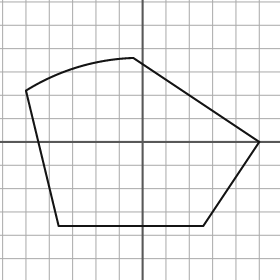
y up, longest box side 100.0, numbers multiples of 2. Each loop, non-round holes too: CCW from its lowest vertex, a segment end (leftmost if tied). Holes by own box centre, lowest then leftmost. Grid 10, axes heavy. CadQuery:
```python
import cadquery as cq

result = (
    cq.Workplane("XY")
    .moveTo(-36.0, -36.0)
    .lineTo(26.0, -36.0)
    .lineTo(50.0, 0.0)
    .lineTo(-4.0, 36.0)
    .threePointArc((-28.0, 32.0), (-50.0, 22.0))
    .close()
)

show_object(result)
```